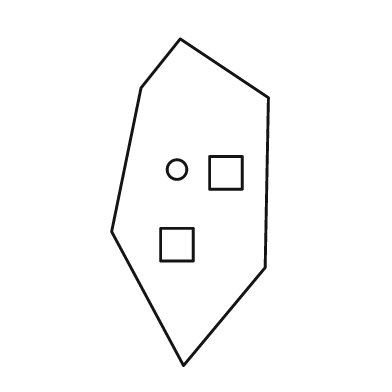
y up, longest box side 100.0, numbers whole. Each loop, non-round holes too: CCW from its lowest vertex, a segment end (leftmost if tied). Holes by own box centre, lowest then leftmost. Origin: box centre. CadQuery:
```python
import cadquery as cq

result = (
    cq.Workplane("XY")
    .moveTo(-2.0, -50.0)
    .lineTo(23.0, -20.0)
    .lineTo(24.0, 32.0)
    .lineTo(-3.0, 50.0)
    .lineTo(-15.0, 35.0)
    .lineTo(-24.0, -9.0)
    .close()
    .moveTo(-9.0, -18.0)
    .lineTo(1.0, -18.0)
    .lineTo(1.0, -8.0)
    .lineTo(-9.0, -8.0)
    .close()
    .moveTo(6.0, 4.0)
    .lineTo(16.0, 4.0)
    .lineTo(16.0, 14.0)
    .lineTo(6.0, 14.0)
    .close()
    .moveTo(-4.0, 10.0)
    .circle(3.0)
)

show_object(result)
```